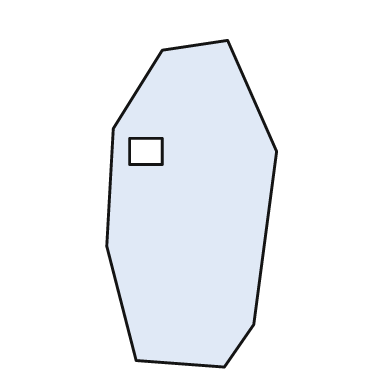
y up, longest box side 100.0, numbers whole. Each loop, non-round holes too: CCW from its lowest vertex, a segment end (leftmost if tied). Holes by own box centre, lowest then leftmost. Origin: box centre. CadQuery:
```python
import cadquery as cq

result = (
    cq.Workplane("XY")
    .moveTo(10.0, -50.0)
    .lineTo(19.0, -37.0)
    .lineTo(26.0, 16.0)
    .lineTo(11.0, 50.0)
    .lineTo(-9.0, 47.0)
    .lineTo(-24.0, 23.0)
    .lineTo(-26.0, -13.0)
    .lineTo(-17.0, -48.0)
    .close()
    .moveTo(-19.0, 12.0)
    .lineTo(-9.0, 12.0)
    .lineTo(-9.0, 20.0)
    .lineTo(-19.0, 20.0)
    .close()
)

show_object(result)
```